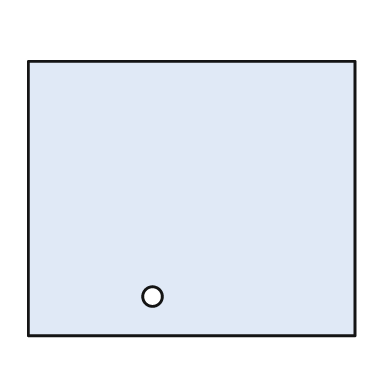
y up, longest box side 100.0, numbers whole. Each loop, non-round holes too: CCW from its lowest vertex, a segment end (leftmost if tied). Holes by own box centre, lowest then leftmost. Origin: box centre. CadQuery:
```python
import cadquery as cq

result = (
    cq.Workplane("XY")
    .moveTo(-50.0, -42.0)
    .lineTo(50.0, -42.0)
    .lineTo(50.0, 42.0)
    .lineTo(-50.0, 42.0)
    .close()
    .moveTo(-12.0, -30.0)
    .circle(3.0)
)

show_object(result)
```